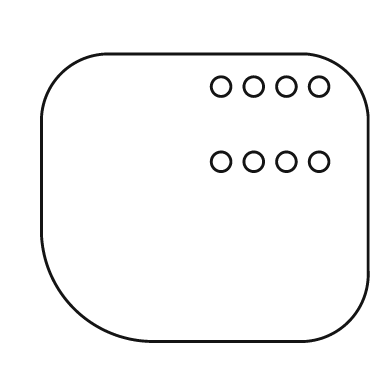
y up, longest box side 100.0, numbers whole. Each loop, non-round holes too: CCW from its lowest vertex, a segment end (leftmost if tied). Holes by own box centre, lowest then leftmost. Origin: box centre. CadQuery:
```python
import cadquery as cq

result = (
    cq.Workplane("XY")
    .moveTo(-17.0, -44.0)
    .lineTo(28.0, -44.0)
    .threePointArc((44.0, -38.0), (50.0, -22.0))
    .lineTo(50.0, 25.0)
    .threePointArc((44.0, 38.0), (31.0, 44.0))
    .lineTo(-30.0, 44.0)
    .threePointArc((-44.0, 38.0), (-50.0, 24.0))
    .lineTo(-50.0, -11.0)
    .threePointArc((-40.0, -34.0), (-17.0, -44.0))
    .close()
    .moveTo(5.0, 11.0)
    .circle(3.0)
    .moveTo(15.0, 11.0)
    .circle(3.0)
    .moveTo(25.0, 11.0)
    .circle(3.0)
    .moveTo(35.0, 11.0)
    .circle(3.0)
    .moveTo(5.0, 34.0)
    .circle(3.0)
    .moveTo(15.0, 34.0)
    .circle(3.0)
    .moveTo(25.0, 34.0)
    .circle(3.0)
    .moveTo(35.0, 34.0)
    .circle(3.0)
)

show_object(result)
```